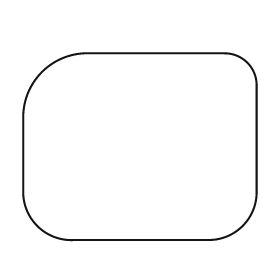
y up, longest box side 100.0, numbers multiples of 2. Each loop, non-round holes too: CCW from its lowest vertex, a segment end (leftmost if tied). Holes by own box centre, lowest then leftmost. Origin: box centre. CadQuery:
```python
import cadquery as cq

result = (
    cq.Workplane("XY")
    .moveTo(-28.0, -40.0)
    .lineTo(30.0, -40.0)
    .threePointArc((44.0, -34.0), (50.0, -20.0))
    .lineTo(50.0, 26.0)
    .threePointArc((46.0, 36.0), (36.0, 40.0))
    .lineTo(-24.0, 40.0)
    .threePointArc((-42.0, 32.0), (-50.0, 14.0))
    .lineTo(-50.0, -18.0)
    .threePointArc((-44.0, -34.0), (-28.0, -40.0))
    .close()
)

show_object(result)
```